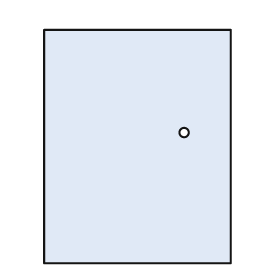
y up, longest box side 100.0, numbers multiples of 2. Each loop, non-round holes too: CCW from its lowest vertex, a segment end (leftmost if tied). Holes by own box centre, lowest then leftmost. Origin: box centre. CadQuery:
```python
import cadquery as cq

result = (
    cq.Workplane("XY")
    .moveTo(-40.0, -50.0)
    .lineTo(40.0, -50.0)
    .lineTo(40.0, 50.0)
    .lineTo(-40.0, 50.0)
    .close()
    .moveTo(20.0, 6.0)
    .circle(2.0)
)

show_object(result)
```